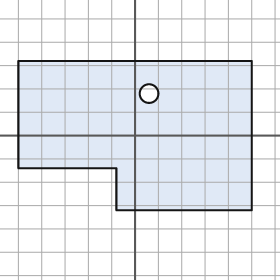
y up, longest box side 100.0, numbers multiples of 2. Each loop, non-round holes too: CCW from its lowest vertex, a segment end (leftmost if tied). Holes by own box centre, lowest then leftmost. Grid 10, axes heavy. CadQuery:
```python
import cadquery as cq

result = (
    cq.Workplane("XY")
    .moveTo(-8.0, -32.0)
    .lineTo(50.0, -32.0)
    .lineTo(50.0, 32.0)
    .lineTo(-50.0, 32.0)
    .lineTo(-50.0, -14.0)
    .lineTo(-8.0, -14.0)
    .close()
    .moveTo(6.0, 18.0)
    .circle(4.0)
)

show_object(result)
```